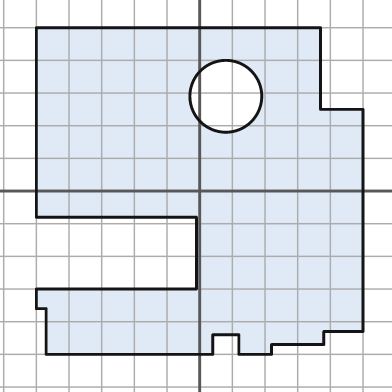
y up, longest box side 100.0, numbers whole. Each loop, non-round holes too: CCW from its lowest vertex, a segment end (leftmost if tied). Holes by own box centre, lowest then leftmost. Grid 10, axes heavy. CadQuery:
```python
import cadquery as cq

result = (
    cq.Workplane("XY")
    .moveTo(-47.0, -50.0)
    .lineTo(4.0, -50.0)
    .lineTo(4.0, -44.0)
    .lineTo(12.0, -44.0)
    .lineTo(12.0, -50.0)
    .lineTo(22.0, -50.0)
    .lineTo(22.0, -47.0)
    .lineTo(38.0, -47.0)
    .lineTo(38.0, -43.0)
    .lineTo(50.0, -43.0)
    .lineTo(50.0, 25.0)
    .lineTo(37.0, 25.0)
    .lineTo(37.0, 50.0)
    .lineTo(-50.0, 50.0)
    .lineTo(-50.0, -8.0)
    .lineTo(-1.0, -8.0)
    .lineTo(-1.0, -30.0)
    .lineTo(-50.0, -30.0)
    .lineTo(-50.0, -36.0)
    .lineTo(-47.0, -36.0)
    .close()
    .moveTo(8.0, 29.0)
    .circle(11.0)
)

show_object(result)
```